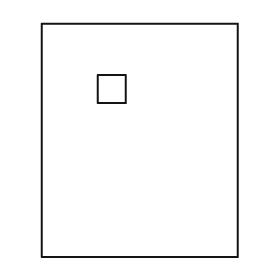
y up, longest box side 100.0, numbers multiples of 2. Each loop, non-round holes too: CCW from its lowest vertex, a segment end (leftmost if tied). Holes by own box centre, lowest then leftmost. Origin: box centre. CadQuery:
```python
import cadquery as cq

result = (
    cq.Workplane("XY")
    .moveTo(-42.0, -50.0)
    .lineTo(42.0, -50.0)
    .lineTo(42.0, 50.0)
    .lineTo(-42.0, 50.0)
    .close()
    .moveTo(-18.0, 16.0)
    .lineTo(-6.0, 16.0)
    .lineTo(-6.0, 28.0)
    .lineTo(-18.0, 28.0)
    .close()
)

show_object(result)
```